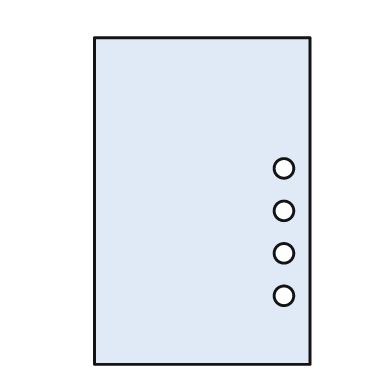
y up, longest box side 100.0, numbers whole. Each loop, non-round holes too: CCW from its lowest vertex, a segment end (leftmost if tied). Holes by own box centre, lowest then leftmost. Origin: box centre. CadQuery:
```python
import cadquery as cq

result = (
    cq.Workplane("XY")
    .moveTo(-33.0, -50.0)
    .lineTo(33.0, -50.0)
    .lineTo(33.0, 50.0)
    .lineTo(-33.0, 50.0)
    .close()
    .moveTo(25.0, -29.0)
    .circle(3.0)
    .moveTo(25.0, -16.0)
    .circle(3.0)
    .moveTo(25.0, -3.0)
    .circle(3.0)
    .moveTo(25.0, 10.0)
    .circle(3.0)
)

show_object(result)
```